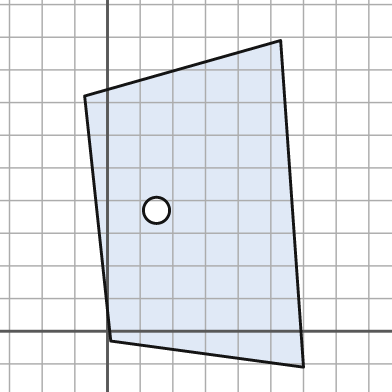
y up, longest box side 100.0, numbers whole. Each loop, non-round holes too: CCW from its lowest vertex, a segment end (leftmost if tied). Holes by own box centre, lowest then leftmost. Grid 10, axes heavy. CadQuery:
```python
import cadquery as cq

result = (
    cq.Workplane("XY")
    .moveTo(60.0, -11.0)
    .lineTo(53.0, 89.0)
    .lineTo(-7.0, 72.0)
    .lineTo(1.0, -3.0)
    .close()
    .moveTo(15.0, 37.0)
    .circle(4.0)
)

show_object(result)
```